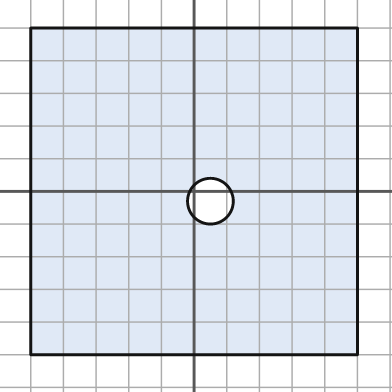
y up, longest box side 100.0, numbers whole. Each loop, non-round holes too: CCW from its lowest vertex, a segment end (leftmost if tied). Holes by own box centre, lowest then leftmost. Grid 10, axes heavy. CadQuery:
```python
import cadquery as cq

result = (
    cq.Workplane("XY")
    .moveTo(-50.0, -50.0)
    .lineTo(50.0, -50.0)
    .lineTo(50.0, 50.0)
    .lineTo(-50.0, 50.0)
    .close()
    .moveTo(5.0, -3.0)
    .circle(7.0)
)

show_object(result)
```